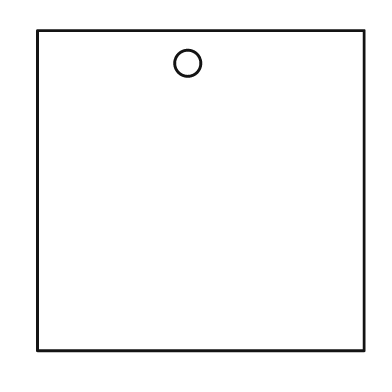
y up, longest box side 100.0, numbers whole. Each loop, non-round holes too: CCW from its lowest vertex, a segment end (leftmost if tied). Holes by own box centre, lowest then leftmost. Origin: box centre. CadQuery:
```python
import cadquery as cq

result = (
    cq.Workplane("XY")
    .moveTo(-50.0, -49.0)
    .lineTo(50.0, -49.0)
    .lineTo(50.0, 49.0)
    .lineTo(-50.0, 49.0)
    .close()
    .moveTo(-4.0, 39.0)
    .circle(4.0)
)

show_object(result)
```